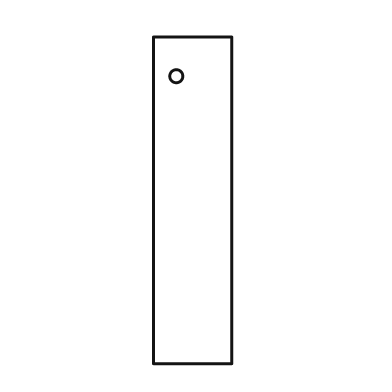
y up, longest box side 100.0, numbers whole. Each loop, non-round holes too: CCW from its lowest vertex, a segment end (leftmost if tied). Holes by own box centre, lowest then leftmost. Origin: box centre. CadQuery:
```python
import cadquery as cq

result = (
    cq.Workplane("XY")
    .moveTo(-12.0, -50.0)
    .lineTo(12.0, -50.0)
    .lineTo(12.0, 50.0)
    .lineTo(-12.0, 50.0)
    .close()
    .moveTo(-5.0, 38.0)
    .circle(2.0)
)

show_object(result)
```